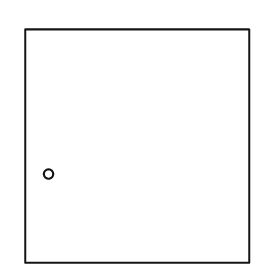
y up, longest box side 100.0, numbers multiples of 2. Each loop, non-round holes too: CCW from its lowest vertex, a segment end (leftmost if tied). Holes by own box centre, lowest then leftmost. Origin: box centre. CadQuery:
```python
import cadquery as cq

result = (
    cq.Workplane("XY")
    .moveTo(-48.0, -50.0)
    .lineTo(48.0, -50.0)
    .lineTo(48.0, 50.0)
    .lineTo(-48.0, 50.0)
    .close()
    .moveTo(-38.0, -12.0)
    .circle(2.0)
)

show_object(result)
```